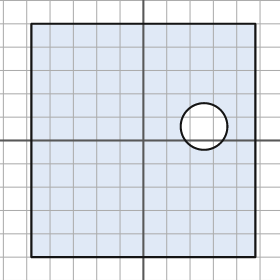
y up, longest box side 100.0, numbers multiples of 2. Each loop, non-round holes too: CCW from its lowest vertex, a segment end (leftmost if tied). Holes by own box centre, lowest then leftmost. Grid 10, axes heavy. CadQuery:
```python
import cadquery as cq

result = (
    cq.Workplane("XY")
    .moveTo(-48.0, -50.0)
    .lineTo(48.0, -50.0)
    .lineTo(48.0, 50.0)
    .lineTo(-48.0, 50.0)
    .close()
    .moveTo(26.0, 6.0)
    .circle(10.0)
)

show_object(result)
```